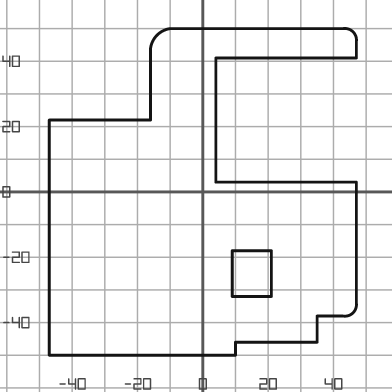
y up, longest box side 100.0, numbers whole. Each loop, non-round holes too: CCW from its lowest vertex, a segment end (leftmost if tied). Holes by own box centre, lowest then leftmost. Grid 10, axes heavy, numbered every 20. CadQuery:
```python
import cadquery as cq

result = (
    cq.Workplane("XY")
    .moveTo(-47.0, -50.0)
    .lineTo(10.0, -50.0)
    .lineTo(10.0, -46.0)
    .lineTo(35.0, -46.0)
    .lineTo(35.0, -38.0)
    .lineTo(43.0, -38.0)
    .threePointArc((46.0, -37.0), (47.0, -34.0))
    .lineTo(47.0, 3.0)
    .lineTo(4.0, 3.0)
    .lineTo(4.0, 41.0)
    .lineTo(47.0, 41.0)
    .lineTo(47.0, 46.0)
    .threePointArc((46.0, 49.0), (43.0, 50.0))
    .lineTo(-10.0, 50.0)
    .threePointArc((-14.0, 48.0), (-16.0, 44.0))
    .lineTo(-16.0, 22.0)
    .lineTo(-47.0, 22.0)
    .close()
    .moveTo(9.0, -32.0)
    .lineTo(21.0, -32.0)
    .lineTo(21.0, -18.0)
    .lineTo(9.0, -18.0)
    .close()
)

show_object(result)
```